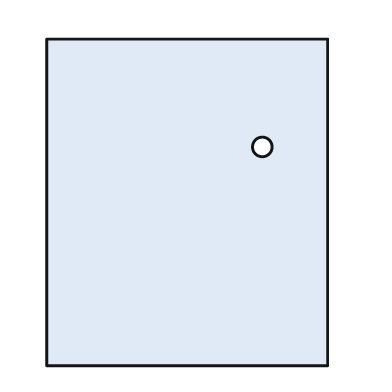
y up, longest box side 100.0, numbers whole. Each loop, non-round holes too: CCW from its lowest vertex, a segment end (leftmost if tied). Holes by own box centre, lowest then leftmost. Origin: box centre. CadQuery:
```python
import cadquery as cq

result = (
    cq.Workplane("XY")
    .moveTo(-43.0, -50.0)
    .lineTo(43.0, -50.0)
    .lineTo(43.0, 50.0)
    .lineTo(-43.0, 50.0)
    .close()
    .moveTo(23.0, 17.0)
    .circle(3.0)
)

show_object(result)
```